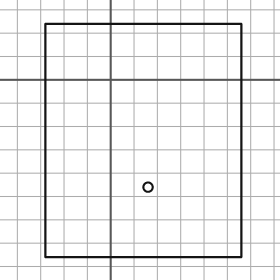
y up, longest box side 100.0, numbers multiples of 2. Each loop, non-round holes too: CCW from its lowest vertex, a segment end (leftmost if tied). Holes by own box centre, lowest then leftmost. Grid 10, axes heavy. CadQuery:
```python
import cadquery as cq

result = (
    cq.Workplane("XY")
    .moveTo(-28.0, -76.0)
    .lineTo(56.0, -76.0)
    .lineTo(56.0, 24.0)
    .lineTo(-28.0, 24.0)
    .close()
    .moveTo(16.0, -46.0)
    .circle(2.0)
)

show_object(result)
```